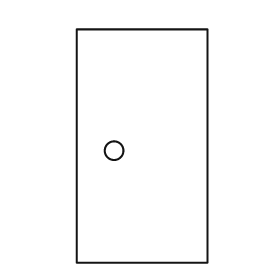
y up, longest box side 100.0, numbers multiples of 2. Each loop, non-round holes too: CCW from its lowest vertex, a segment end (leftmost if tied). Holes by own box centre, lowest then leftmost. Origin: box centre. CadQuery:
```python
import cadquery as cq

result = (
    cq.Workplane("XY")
    .moveTo(-28.0, -50.0)
    .lineTo(28.0, -50.0)
    .lineTo(28.0, 50.0)
    .lineTo(-28.0, 50.0)
    .close()
    .moveTo(-12.0, -2.0)
    .circle(4.0)
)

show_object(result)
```